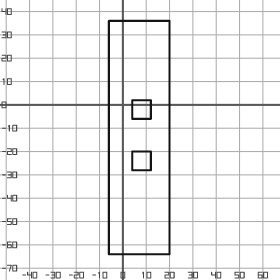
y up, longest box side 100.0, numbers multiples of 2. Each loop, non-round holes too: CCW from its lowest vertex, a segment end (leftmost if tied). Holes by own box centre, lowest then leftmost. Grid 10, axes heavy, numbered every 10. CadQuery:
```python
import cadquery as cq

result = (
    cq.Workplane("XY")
    .moveTo(-6.0, -64.0)
    .lineTo(20.0, -64.0)
    .lineTo(20.0, 36.0)
    .lineTo(-6.0, 36.0)
    .close()
    .moveTo(4.0, -28.0)
    .lineTo(12.0, -28.0)
    .lineTo(12.0, -20.0)
    .lineTo(4.0, -20.0)
    .close()
    .moveTo(4.0, -6.0)
    .lineTo(12.0, -6.0)
    .lineTo(12.0, 2.0)
    .lineTo(4.0, 2.0)
    .close()
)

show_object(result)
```